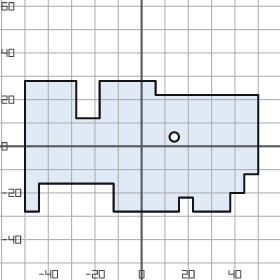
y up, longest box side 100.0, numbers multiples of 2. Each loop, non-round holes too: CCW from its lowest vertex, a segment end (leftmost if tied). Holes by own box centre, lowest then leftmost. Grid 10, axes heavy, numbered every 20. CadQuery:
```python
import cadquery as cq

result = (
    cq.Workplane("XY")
    .moveTo(-50.0, -28.0)
    .lineTo(-44.0, -28.0)
    .lineTo(-44.0, -16.0)
    .lineTo(-12.0, -16.0)
    .lineTo(-12.0, -28.0)
    .lineTo(16.0, -28.0)
    .lineTo(16.0, -22.0)
    .lineTo(22.0, -22.0)
    .lineTo(22.0, -28.0)
    .lineTo(38.0, -28.0)
    .lineTo(38.0, -20.0)
    .lineTo(44.0, -20.0)
    .lineTo(44.0, -12.0)
    .lineTo(50.0, -12.0)
    .lineTo(50.0, 22.0)
    .lineTo(6.0, 22.0)
    .lineTo(6.0, 28.0)
    .lineTo(-18.0, 28.0)
    .lineTo(-18.0, 12.0)
    .lineTo(-28.0, 12.0)
    .lineTo(-28.0, 28.0)
    .lineTo(-50.0, 28.0)
    .close()
    .moveTo(14.0, 4.0)
    .circle(2.0)
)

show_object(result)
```